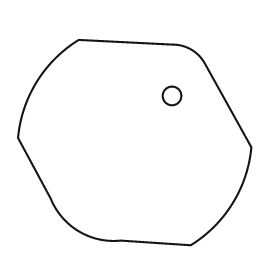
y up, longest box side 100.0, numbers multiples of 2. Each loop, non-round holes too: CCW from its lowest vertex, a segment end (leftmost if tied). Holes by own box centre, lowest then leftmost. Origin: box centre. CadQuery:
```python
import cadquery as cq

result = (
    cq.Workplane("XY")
    .moveTo(24.0, -44.0)
    .threePointArc((42.0, -26.0), (50.0, -2.0))
    .lineTo(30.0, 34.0)
    .threePointArc((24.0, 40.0), (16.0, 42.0))
    .lineTo(-24.0, 44.0)
    .threePointArc((-42.0, 26.0), (-50.0, 2.0))
    .lineTo(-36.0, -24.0)
    .threePointArc((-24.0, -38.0), (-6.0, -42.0))
    .close()
    .moveTo(16.0, 20.0)
    .circle(4.0)
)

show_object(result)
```